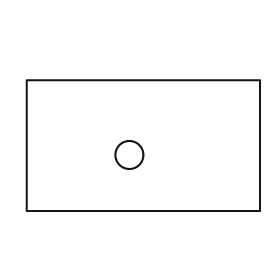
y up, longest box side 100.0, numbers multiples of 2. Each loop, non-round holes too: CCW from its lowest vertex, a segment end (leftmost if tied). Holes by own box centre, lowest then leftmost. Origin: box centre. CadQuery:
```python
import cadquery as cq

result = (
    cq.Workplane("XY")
    .moveTo(-50.0, -28.0)
    .lineTo(50.0, -28.0)
    .lineTo(50.0, 28.0)
    .lineTo(-50.0, 28.0)
    .close()
    .moveTo(-6.0, -4.0)
    .circle(6.0)
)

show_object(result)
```